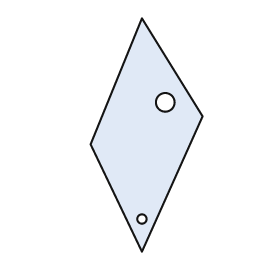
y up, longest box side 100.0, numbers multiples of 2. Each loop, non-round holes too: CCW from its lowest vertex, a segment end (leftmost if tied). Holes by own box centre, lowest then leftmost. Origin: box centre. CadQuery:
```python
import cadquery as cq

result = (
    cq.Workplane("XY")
    .moveTo(-2.0, -50.0)
    .lineTo(24.0, 8.0)
    .lineTo(-2.0, 50.0)
    .lineTo(-24.0, -4.0)
    .close()
    .moveTo(-2.0, -36.0)
    .circle(2.0)
    .moveTo(8.0, 14.0)
    .circle(4.0)
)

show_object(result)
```